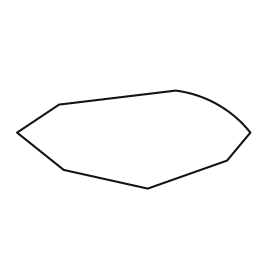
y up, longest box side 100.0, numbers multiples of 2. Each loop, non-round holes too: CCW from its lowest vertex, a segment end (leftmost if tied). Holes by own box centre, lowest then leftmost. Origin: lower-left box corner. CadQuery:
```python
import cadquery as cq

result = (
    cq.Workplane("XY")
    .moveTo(56.0, 0.0)
    .lineTo(90.0, 12.0)
    .lineTo(100.0, 24.0)
    .threePointArc((86.0, 36.0), (68.0, 42.0))
    .lineTo(18.0, 36.0)
    .lineTo(0.0, 24.0)
    .lineTo(20.0, 8.0)
    .close()
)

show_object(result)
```